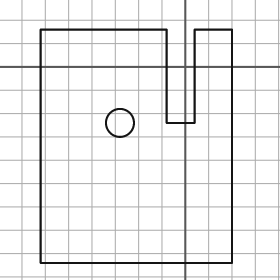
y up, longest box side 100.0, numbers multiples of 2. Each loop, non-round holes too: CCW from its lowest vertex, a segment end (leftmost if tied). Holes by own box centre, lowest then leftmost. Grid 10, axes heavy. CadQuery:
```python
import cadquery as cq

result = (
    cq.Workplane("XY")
    .moveTo(-62.0, -84.0)
    .lineTo(20.0, -84.0)
    .lineTo(20.0, 16.0)
    .lineTo(4.0, 16.0)
    .lineTo(4.0, -24.0)
    .lineTo(-8.0, -24.0)
    .lineTo(-8.0, 16.0)
    .lineTo(-62.0, 16.0)
    .close()
    .moveTo(-28.0, -24.0)
    .circle(6.0)
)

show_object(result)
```